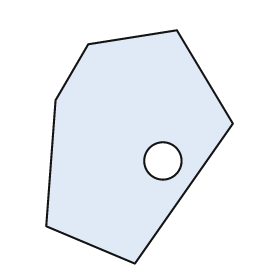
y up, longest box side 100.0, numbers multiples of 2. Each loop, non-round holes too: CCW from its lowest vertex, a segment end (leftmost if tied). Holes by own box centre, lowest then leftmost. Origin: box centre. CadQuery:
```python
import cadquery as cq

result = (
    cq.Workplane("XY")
    .moveTo(-2.0, -50.0)
    .lineTo(40.0, 10.0)
    .lineTo(16.0, 50.0)
    .lineTo(-22.0, 44.0)
    .lineTo(-36.0, 20.0)
    .lineTo(-40.0, -34.0)
    .close()
    .moveTo(10.0, -6.0)
    .circle(8.0)
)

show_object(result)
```